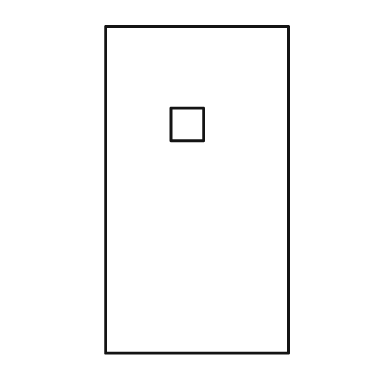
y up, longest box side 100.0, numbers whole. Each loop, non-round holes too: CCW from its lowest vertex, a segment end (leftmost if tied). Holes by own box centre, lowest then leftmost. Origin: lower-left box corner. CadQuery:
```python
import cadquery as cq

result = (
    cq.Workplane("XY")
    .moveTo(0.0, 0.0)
    .lineTo(56.0, 0.0)
    .lineTo(56.0, 100.0)
    .lineTo(0.0, 100.0)
    .close()
    .moveTo(20.0, 65.0)
    .lineTo(30.0, 65.0)
    .lineTo(30.0, 75.0)
    .lineTo(20.0, 75.0)
    .close()
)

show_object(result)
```